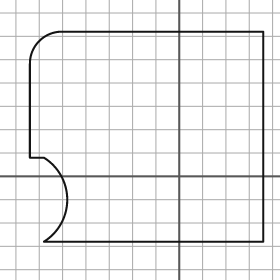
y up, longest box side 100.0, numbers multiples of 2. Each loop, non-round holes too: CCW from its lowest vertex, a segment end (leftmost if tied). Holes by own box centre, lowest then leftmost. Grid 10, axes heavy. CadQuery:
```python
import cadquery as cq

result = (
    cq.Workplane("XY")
    .moveTo(-58.0, -28.0)
    .lineTo(36.0, -28.0)
    .lineTo(36.0, 62.0)
    .lineTo(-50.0, 62.0)
    .threePointArc((-60.0, 58.0), (-64.0, 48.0))
    .lineTo(-64.0, 8.0)
    .lineTo(-58.0, 8.0)
    .threePointArc((-48.0, -10.0), (-58.0, -28.0))
    .close()
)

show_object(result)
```